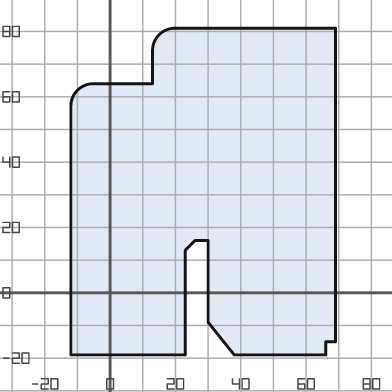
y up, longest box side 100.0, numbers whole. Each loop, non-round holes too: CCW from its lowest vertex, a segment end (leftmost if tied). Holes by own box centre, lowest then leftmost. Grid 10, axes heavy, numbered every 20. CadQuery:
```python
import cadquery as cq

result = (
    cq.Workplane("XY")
    .moveTo(-12.0, -19.0)
    .lineTo(23.0, -19.0)
    .lineTo(23.0, 13.0)
    .lineTo(26.0, 16.0)
    .lineTo(30.0, 16.0)
    .lineTo(30.0, -9.0)
    .lineTo(38.0, -19.0)
    .lineTo(66.0, -19.0)
    .lineTo(66.0, -15.0)
    .lineTo(69.0, -15.0)
    .lineTo(69.0, 81.0)
    .lineTo(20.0, 81.0)
    .threePointArc((15.0, 79.0), (13.0, 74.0))
    .lineTo(13.0, 64.0)
    .lineTo(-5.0, 64.0)
    .threePointArc((-10.0, 62.0), (-12.0, 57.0))
    .close()
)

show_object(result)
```